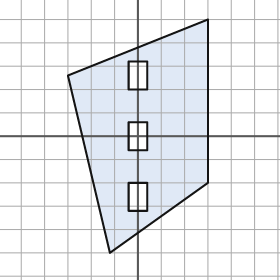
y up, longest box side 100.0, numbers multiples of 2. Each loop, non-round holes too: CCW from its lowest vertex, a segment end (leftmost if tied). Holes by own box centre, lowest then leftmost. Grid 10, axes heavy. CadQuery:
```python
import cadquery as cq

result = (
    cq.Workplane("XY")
    .moveTo(-12.0, -50.0)
    .lineTo(30.0, -20.0)
    .lineTo(30.0, 50.0)
    .lineTo(-30.0, 26.0)
    .close()
    .moveTo(-4.0, -32.0)
    .lineTo(4.0, -32.0)
    .lineTo(4.0, -20.0)
    .lineTo(-4.0, -20.0)
    .close()
    .moveTo(-4.0, -6.0)
    .lineTo(4.0, -6.0)
    .lineTo(4.0, 6.0)
    .lineTo(-4.0, 6.0)
    .close()
    .moveTo(-4.0, 20.0)
    .lineTo(4.0, 20.0)
    .lineTo(4.0, 32.0)
    .lineTo(-4.0, 32.0)
    .close()
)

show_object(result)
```